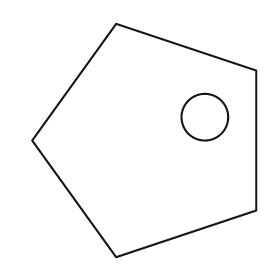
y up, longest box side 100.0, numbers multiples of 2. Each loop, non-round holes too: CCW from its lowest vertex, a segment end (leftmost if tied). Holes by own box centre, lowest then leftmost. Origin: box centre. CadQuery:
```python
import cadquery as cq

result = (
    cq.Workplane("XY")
    .moveTo(-12.0, -50.0)
    .lineTo(48.0, -30.0)
    .lineTo(48.0, 30.0)
    .lineTo(-12.0, 50.0)
    .lineTo(-48.0, 0.0)
    .close()
    .moveTo(26.0, 10.0)
    .circle(10.0)
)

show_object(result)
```